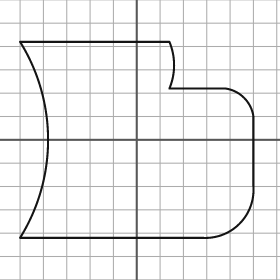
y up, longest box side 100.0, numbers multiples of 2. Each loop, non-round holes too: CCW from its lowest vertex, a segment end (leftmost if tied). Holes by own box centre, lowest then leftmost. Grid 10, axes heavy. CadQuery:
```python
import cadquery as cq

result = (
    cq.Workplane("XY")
    .moveTo(-50.0, -42.0)
    .lineTo(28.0, -42.0)
    .threePointArc((44.0, -36.0), (50.0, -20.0))
    .lineTo(50.0, 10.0)
    .threePointArc((46.0, 18.0), (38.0, 22.0))
    .lineTo(14.0, 22.0)
    .threePointArc((16.0, 32.0), (14.0, 42.0))
    .lineTo(-50.0, 42.0)
    .threePointArc((-38.0, 0.0), (-50.0, -42.0))
    .close()
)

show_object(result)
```